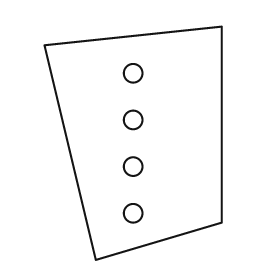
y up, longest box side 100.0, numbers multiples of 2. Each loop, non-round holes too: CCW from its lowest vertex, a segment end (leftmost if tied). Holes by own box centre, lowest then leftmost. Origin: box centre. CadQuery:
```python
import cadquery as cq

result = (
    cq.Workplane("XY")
    .moveTo(-16.0, -50.0)
    .lineTo(38.0, -34.0)
    .lineTo(38.0, 50.0)
    .lineTo(-38.0, 42.0)
    .close()
    .moveTo(0.0, -30.0)
    .circle(4.0)
    .moveTo(0.0, -10.0)
    .circle(4.0)
    .moveTo(0.0, 10.0)
    .circle(4.0)
    .moveTo(0.0, 30.0)
    .circle(4.0)
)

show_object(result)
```